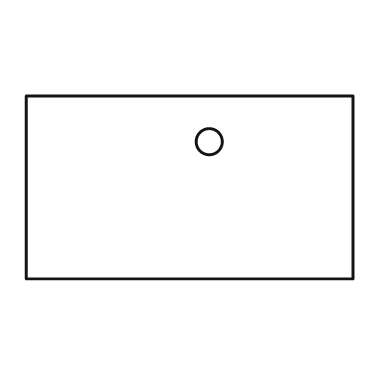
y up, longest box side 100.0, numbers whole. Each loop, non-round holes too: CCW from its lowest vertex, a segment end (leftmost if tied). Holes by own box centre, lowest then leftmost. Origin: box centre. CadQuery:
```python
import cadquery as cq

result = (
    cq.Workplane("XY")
    .moveTo(-50.0, -28.0)
    .lineTo(50.0, -28.0)
    .lineTo(50.0, 28.0)
    .lineTo(-50.0, 28.0)
    .close()
    .moveTo(6.0, 14.0)
    .circle(4.0)
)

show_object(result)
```